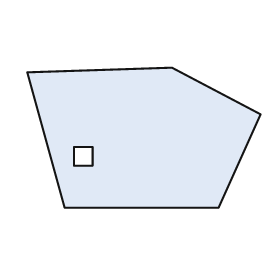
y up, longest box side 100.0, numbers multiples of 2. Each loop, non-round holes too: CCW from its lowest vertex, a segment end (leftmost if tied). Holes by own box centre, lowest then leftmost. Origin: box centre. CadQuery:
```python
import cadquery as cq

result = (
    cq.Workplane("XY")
    .moveTo(-34.0, -30.0)
    .lineTo(32.0, -30.0)
    .lineTo(50.0, 10.0)
    .lineTo(12.0, 30.0)
    .lineTo(-50.0, 28.0)
    .close()
    .moveTo(-30.0, -12.0)
    .lineTo(-22.0, -12.0)
    .lineTo(-22.0, -4.0)
    .lineTo(-30.0, -4.0)
    .close()
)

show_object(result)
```